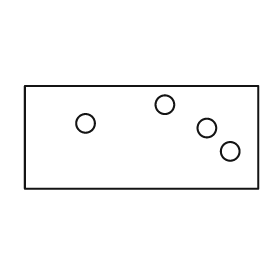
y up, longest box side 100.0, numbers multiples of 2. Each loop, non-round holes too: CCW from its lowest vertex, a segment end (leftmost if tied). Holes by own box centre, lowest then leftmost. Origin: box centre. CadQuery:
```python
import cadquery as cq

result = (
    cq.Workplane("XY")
    .moveTo(-50.0, -22.0)
    .lineTo(50.0, -22.0)
    .lineTo(50.0, 22.0)
    .lineTo(-50.0, 22.0)
    .close()
    .moveTo(38.0, -6.0)
    .circle(4.0)
    .moveTo(28.0, 4.0)
    .circle(4.0)
    .moveTo(-24.0, 6.0)
    .circle(4.0)
    .moveTo(10.0, 14.0)
    .circle(4.0)
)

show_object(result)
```